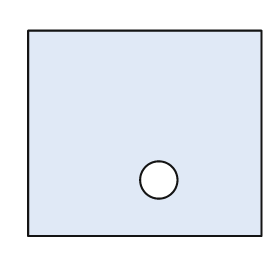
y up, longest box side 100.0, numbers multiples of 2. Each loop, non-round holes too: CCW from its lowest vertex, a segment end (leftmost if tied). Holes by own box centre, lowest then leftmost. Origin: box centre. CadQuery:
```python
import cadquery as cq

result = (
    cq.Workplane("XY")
    .moveTo(-50.0, -44.0)
    .lineTo(50.0, -44.0)
    .lineTo(50.0, 44.0)
    .lineTo(-50.0, 44.0)
    .close()
    .moveTo(6.0, -20.0)
    .circle(8.0)
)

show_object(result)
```